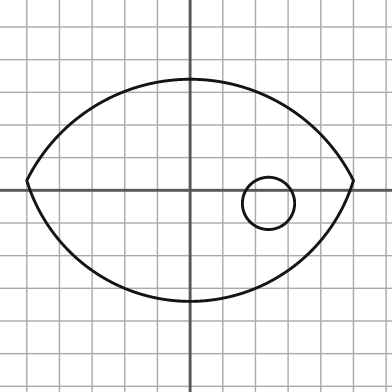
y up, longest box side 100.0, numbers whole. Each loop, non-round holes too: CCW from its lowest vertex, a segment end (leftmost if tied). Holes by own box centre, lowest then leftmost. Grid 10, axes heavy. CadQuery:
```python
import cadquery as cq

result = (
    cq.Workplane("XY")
    .moveTo(-50.0, 3.0)
    .threePointArc((0.0, -34.0), (50.0, 3.0))
    .threePointArc((0.0, 34.0), (-50.0, 3.0))
    .close()
    .moveTo(24.0, -4.0)
    .circle(8.0)
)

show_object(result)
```